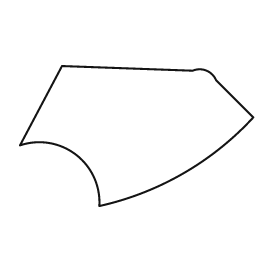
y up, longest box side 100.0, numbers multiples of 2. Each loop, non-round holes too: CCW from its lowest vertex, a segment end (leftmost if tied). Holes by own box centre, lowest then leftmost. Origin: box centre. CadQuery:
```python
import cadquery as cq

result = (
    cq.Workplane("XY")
    .moveTo(-16.0, -30.0)
    .threePointArc((20.0, -16.0), (50.0, 8.0))
    .lineTo(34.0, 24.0)
    .threePointArc((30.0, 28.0), (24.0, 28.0))
    .lineTo(-32.0, 30.0)
    .lineTo(-50.0, -4.0)
    .threePointArc((-26.0, -8.0), (-16.0, -30.0))
    .close()
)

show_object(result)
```